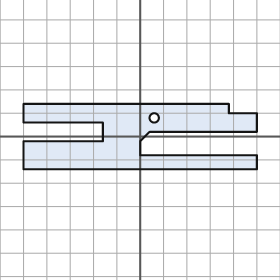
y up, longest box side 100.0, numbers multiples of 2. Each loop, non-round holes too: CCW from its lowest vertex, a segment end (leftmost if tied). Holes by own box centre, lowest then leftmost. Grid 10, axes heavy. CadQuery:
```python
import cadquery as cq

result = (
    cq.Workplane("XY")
    .moveTo(-50.0, -14.0)
    .lineTo(50.0, -14.0)
    .lineTo(50.0, -8.0)
    .lineTo(0.0, -8.0)
    .lineTo(0.0, -2.0)
    .lineTo(4.0, 2.0)
    .lineTo(50.0, 2.0)
    .lineTo(50.0, 10.0)
    .lineTo(38.0, 10.0)
    .lineTo(38.0, 14.0)
    .lineTo(-50.0, 14.0)
    .lineTo(-50.0, 6.0)
    .lineTo(-16.0, 6.0)
    .lineTo(-16.0, -2.0)
    .lineTo(-50.0, -2.0)
    .close()
    .moveTo(6.0, 8.0)
    .circle(2.0)
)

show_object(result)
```